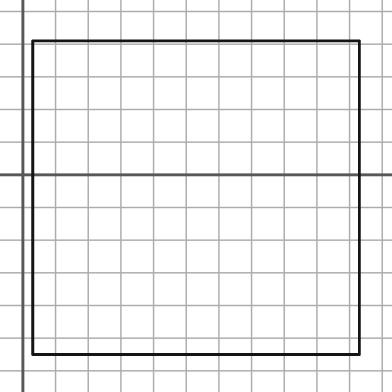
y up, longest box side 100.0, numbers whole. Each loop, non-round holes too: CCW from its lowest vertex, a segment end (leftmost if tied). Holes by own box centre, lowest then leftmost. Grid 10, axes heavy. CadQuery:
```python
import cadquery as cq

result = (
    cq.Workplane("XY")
    .moveTo(3.0, -55.0)
    .lineTo(103.0, -55.0)
    .lineTo(103.0, 41.0)
    .lineTo(3.0, 41.0)
    .close()
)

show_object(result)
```